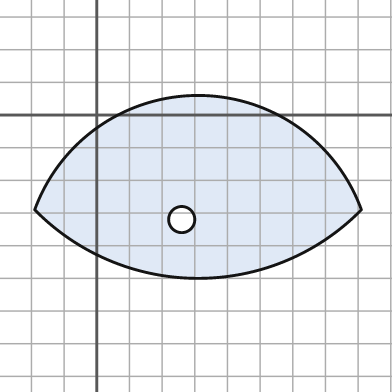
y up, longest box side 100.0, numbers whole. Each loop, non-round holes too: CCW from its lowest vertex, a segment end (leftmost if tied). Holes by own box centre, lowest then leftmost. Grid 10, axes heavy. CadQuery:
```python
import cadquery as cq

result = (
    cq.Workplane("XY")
    .moveTo(-19.0, -29.0)
    .threePointArc((31.0, -50.0), (81.0, -29.0))
    .threePointArc((31.0, 6.0), (-19.0, -29.0))
    .close()
    .moveTo(26.0, -32.0)
    .circle(4.0)
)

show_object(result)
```